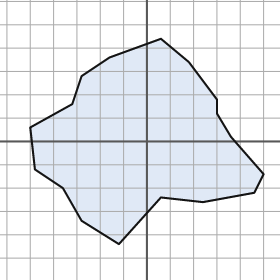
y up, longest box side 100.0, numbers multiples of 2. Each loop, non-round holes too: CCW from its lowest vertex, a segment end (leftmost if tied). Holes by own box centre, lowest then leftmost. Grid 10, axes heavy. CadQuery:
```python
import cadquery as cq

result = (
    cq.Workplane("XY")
    .moveTo(-12.0, -44.0)
    .lineTo(6.0, -24.0)
    .lineTo(24.0, -26.0)
    .lineTo(46.0, -22.0)
    .lineTo(50.0, -14.0)
    .lineTo(36.0, 2.0)
    .lineTo(30.0, 12.0)
    .lineTo(30.0, 18.0)
    .lineTo(18.0, 34.0)
    .lineTo(6.0, 44.0)
    .lineTo(-16.0, 36.0)
    .lineTo(-28.0, 28.0)
    .lineTo(-32.0, 16.0)
    .lineTo(-50.0, 6.0)
    .lineTo(-48.0, -12.0)
    .lineTo(-36.0, -20.0)
    .lineTo(-28.0, -34.0)
    .close()
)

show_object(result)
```